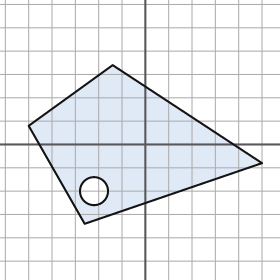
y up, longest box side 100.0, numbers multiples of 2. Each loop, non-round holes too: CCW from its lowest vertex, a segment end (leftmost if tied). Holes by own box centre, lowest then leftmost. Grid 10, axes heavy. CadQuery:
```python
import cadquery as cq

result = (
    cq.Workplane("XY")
    .moveTo(-26.0, -34.0)
    .lineTo(50.0, -8.0)
    .lineTo(-14.0, 34.0)
    .lineTo(-50.0, 8.0)
    .close()
    .moveTo(-22.0, -20.0)
    .circle(6.0)
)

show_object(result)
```